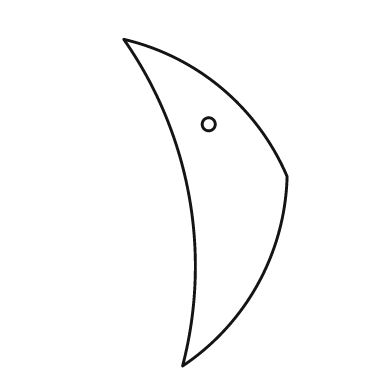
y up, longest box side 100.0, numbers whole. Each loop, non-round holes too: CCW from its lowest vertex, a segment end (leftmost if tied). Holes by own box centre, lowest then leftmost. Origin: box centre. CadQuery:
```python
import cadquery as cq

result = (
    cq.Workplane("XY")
    .moveTo(-7.0, -50.0)
    .threePointArc((16.0, -25.0), (25.0, 8.0))
    .threePointArc((5.0, 35.0), (-25.0, 50.0))
    .threePointArc((-5.0, 2.0), (-7.0, -50.0))
    .close()
    .moveTo(1.0, 24.0)
    .circle(2.0)
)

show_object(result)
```